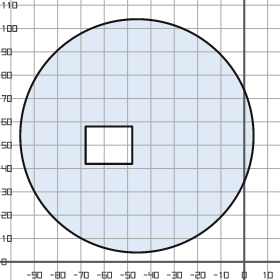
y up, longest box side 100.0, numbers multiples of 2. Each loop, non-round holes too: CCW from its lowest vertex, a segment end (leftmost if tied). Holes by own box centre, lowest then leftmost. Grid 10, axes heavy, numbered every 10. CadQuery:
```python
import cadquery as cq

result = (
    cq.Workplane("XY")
    .moveTo(-46.0, 54.0)
    .circle(50.0)
    .moveTo(-68.0, 42.0)
    .lineTo(-48.0, 42.0)
    .lineTo(-48.0, 58.0)
    .lineTo(-68.0, 58.0)
    .close()
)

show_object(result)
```